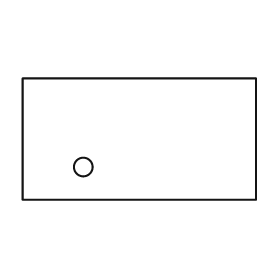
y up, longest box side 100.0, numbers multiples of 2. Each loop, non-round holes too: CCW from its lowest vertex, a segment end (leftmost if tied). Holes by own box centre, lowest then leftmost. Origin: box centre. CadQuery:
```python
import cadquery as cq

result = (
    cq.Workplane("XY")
    .moveTo(-50.0, -26.0)
    .lineTo(50.0, -26.0)
    .lineTo(50.0, 26.0)
    .lineTo(-50.0, 26.0)
    .close()
    .moveTo(-24.0, -12.0)
    .circle(4.0)
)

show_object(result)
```